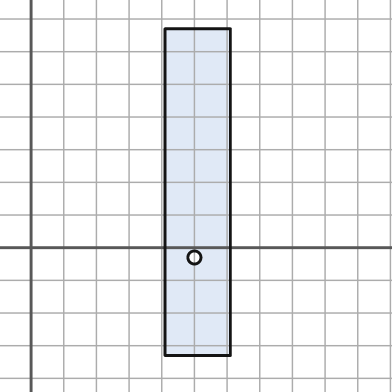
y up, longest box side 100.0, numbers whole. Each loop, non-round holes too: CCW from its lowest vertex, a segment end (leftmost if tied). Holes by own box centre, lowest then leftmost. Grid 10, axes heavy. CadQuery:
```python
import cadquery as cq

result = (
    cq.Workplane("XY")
    .moveTo(41.0, -33.0)
    .lineTo(61.0, -33.0)
    .lineTo(61.0, 67.0)
    .lineTo(41.0, 67.0)
    .close()
    .moveTo(50.0, -3.0)
    .circle(2.0)
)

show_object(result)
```